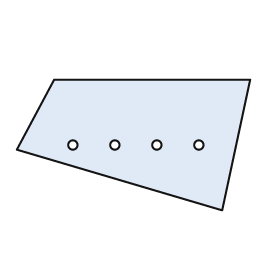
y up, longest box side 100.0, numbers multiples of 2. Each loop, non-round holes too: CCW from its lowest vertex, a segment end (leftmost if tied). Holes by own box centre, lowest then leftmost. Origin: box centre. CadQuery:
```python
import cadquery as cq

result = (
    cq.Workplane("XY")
    .moveTo(38.0, -28.0)
    .lineTo(50.0, 28.0)
    .lineTo(-34.0, 28.0)
    .lineTo(-50.0, -2.0)
    .close()
    .moveTo(-26.0, 0.0)
    .circle(2.0)
    .moveTo(-8.0, 0.0)
    .circle(2.0)
    .moveTo(10.0, 0.0)
    .circle(2.0)
    .moveTo(28.0, 0.0)
    .circle(2.0)
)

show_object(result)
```